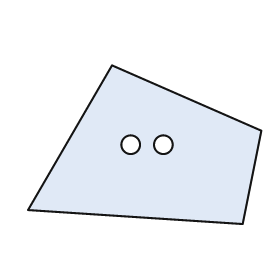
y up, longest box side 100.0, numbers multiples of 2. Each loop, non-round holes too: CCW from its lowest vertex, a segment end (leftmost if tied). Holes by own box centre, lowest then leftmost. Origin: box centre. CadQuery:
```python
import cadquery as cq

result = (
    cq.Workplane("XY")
    .moveTo(42.0, -34.0)
    .lineTo(50.0, 6.0)
    .lineTo(-14.0, 34.0)
    .lineTo(-50.0, -28.0)
    .close()
    .moveTo(-6.0, 0.0)
    .circle(4.0)
    .moveTo(8.0, 0.0)
    .circle(4.0)
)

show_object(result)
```